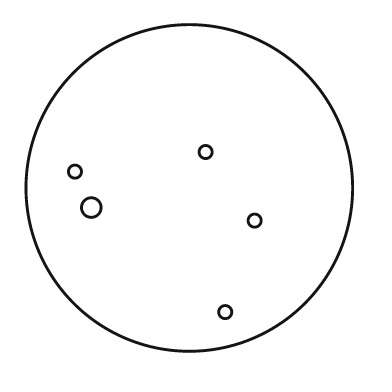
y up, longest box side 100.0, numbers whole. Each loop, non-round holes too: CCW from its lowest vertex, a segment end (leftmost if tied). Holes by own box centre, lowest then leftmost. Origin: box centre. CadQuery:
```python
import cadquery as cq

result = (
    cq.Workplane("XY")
    .moveTo(0.0, 0.0)
    .circle(50.0)
    .moveTo(11.0, -38.0)
    .circle(2.0)
    .moveTo(20.0, -10.0)
    .circle(2.0)
    .moveTo(-30.0, -6.0)
    .circle(3.0)
    .moveTo(-35.0, 5.0)
    .circle(2.0)
    .moveTo(5.0, 11.0)
    .circle(2.0)
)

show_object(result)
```